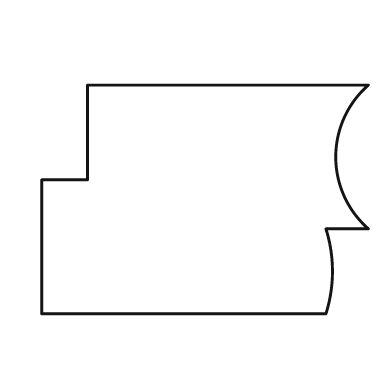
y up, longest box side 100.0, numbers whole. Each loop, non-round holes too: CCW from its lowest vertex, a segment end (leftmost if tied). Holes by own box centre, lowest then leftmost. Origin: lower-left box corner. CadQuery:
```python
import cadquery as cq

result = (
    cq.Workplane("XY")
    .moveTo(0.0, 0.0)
    .lineTo(87.0, 0.0)
    .threePointArc((89.0, 13.0), (87.0, 26.0))
    .lineTo(100.0, 26.0)
    .threePointArc((90.0, 48.0), (100.0, 70.0))
    .lineTo(14.0, 70.0)
    .lineTo(14.0, 41.0)
    .lineTo(0.0, 41.0)
    .close()
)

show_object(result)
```